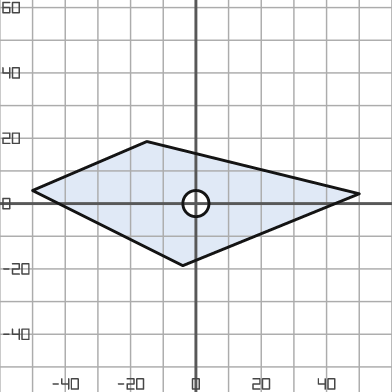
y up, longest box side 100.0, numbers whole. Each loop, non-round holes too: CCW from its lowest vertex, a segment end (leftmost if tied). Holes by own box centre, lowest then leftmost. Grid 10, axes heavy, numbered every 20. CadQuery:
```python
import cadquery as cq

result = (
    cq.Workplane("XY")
    .moveTo(-4.0, -19.0)
    .lineTo(50.0, 3.0)
    .lineTo(-15.0, 19.0)
    .lineTo(-50.0, 4.0)
    .close()
    .moveTo(0.0, 0.0)
    .circle(4.0)
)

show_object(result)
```